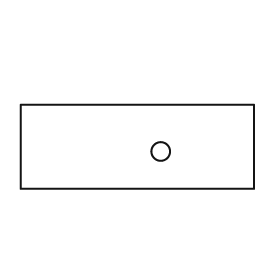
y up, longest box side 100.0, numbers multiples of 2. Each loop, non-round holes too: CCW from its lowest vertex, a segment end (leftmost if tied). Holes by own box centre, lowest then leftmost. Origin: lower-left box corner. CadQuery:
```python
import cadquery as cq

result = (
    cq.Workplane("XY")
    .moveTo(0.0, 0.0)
    .lineTo(100.0, 0.0)
    .lineTo(100.0, 36.0)
    .lineTo(0.0, 36.0)
    .close()
    .moveTo(60.0, 16.0)
    .circle(4.0)
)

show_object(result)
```